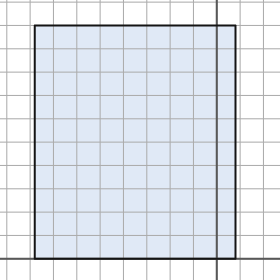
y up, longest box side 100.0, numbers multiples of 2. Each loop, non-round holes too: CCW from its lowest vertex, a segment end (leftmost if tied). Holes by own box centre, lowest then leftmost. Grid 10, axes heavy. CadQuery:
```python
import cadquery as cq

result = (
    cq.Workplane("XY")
    .moveTo(-78.0, 0.0)
    .lineTo(8.0, 0.0)
    .lineTo(8.0, 100.0)
    .lineTo(-78.0, 100.0)
    .close()
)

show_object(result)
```